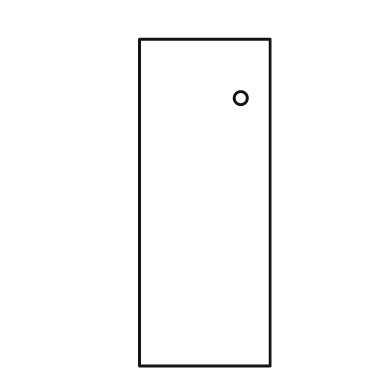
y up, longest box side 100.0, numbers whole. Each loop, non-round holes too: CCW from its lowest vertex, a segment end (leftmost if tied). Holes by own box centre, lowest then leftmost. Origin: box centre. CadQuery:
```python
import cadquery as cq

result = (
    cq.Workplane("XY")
    .moveTo(-20.0, -50.0)
    .lineTo(20.0, -50.0)
    .lineTo(20.0, 50.0)
    .lineTo(-20.0, 50.0)
    .close()
    .moveTo(11.0, 32.0)
    .circle(2.0)
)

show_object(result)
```